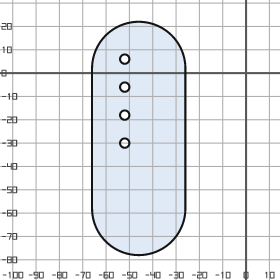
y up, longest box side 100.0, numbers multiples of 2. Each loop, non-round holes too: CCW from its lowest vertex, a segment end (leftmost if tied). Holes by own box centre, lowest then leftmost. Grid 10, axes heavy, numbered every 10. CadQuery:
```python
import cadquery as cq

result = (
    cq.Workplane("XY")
    .moveTo(-66.0, -58.0)
    .threePointArc((-46.0, -78.0), (-26.0, -58.0))
    .lineTo(-26.0, 2.0)
    .threePointArc((-46.0, 22.0), (-66.0, 2.0))
    .close()
    .moveTo(-52.0, -30.0)
    .circle(2.0)
    .moveTo(-52.0, -18.0)
    .circle(2.0)
    .moveTo(-52.0, -6.0)
    .circle(2.0)
    .moveTo(-52.0, 6.0)
    .circle(2.0)
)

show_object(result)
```